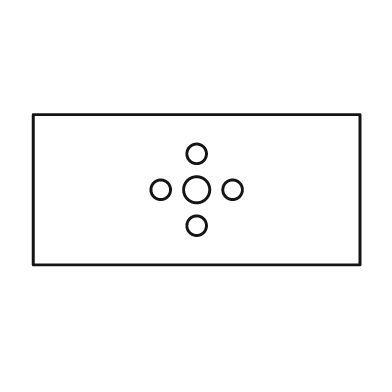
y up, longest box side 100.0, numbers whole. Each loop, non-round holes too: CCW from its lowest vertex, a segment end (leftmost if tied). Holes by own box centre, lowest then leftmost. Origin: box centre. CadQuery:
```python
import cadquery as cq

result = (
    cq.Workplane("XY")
    .moveTo(-50.0, -23.0)
    .lineTo(50.0, -23.0)
    .lineTo(50.0, 23.0)
    .lineTo(-50.0, 23.0)
    .close()
    .moveTo(0.0, -11.0)
    .circle(3.0)
    .moveTo(-11.0, 0.0)
    .circle(3.0)
    .moveTo(0.0, 0.0)
    .circle(4.0)
    .moveTo(11.0, 0.0)
    .circle(3.0)
    .moveTo(0.0, 11.0)
    .circle(3.0)
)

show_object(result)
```